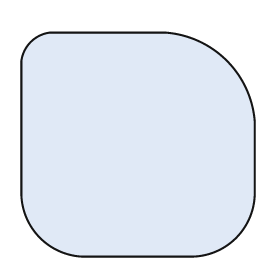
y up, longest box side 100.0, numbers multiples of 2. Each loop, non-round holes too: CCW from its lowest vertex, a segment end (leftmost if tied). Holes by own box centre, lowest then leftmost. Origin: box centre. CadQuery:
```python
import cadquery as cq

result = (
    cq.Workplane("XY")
    .moveTo(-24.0, -48.0)
    .lineTo(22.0, -48.0)
    .threePointArc((42.0, -40.0), (50.0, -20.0))
    .lineTo(50.0, 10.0)
    .threePointArc((38.0, 36.0), (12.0, 48.0))
    .lineTo(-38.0, 48.0)
    .threePointArc((-46.0, 44.0), (-50.0, 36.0))
    .lineTo(-50.0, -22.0)
    .threePointArc((-42.0, -40.0), (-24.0, -48.0))
    .close()
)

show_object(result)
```